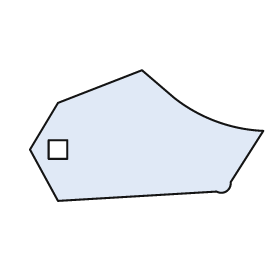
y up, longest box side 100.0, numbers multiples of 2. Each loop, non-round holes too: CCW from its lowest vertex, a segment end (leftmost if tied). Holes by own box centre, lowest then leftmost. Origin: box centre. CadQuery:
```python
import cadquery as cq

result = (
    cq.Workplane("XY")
    .moveTo(-38.0, -28.0)
    .lineTo(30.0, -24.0)
    .threePointArc((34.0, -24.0), (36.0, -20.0))
    .lineTo(50.0, 2.0)
    .threePointArc((30.0, 6.0), (12.0, 16.0))
    .lineTo(-2.0, 28.0)
    .lineTo(-38.0, 14.0)
    .lineTo(-50.0, -6.0)
    .close()
    .moveTo(-42.0, -10.0)
    .lineTo(-34.0, -10.0)
    .lineTo(-34.0, -2.0)
    .lineTo(-42.0, -2.0)
    .close()
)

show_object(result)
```